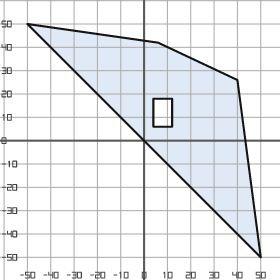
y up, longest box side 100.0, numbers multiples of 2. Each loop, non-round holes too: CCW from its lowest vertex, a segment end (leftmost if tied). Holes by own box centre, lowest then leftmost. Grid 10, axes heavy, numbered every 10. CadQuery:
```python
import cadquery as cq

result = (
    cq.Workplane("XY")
    .moveTo(50.0, -50.0)
    .lineTo(40.0, 26.0)
    .lineTo(6.0, 42.0)
    .lineTo(-50.0, 50.0)
    .close()
    .moveTo(4.0, 6.0)
    .lineTo(12.0, 6.0)
    .lineTo(12.0, 18.0)
    .lineTo(4.0, 18.0)
    .close()
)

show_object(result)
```